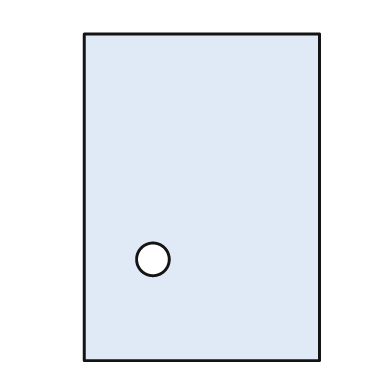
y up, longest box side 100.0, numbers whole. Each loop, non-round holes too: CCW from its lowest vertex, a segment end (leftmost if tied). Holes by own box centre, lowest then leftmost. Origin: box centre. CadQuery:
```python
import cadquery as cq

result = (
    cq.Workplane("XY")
    .moveTo(-36.0, -50.0)
    .lineTo(36.0, -50.0)
    .lineTo(36.0, 50.0)
    .lineTo(-36.0, 50.0)
    .close()
    .moveTo(-15.0, -19.0)
    .circle(5.0)
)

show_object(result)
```